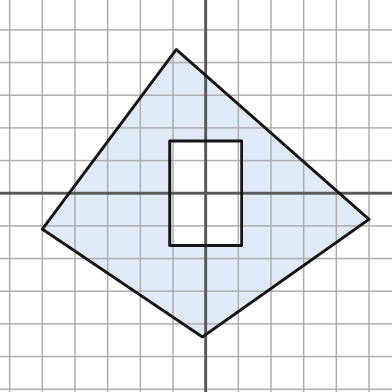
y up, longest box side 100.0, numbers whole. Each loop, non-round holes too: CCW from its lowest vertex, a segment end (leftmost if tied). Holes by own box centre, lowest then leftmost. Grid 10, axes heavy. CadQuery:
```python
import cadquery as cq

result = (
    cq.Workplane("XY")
    .moveTo(-1.0, -44.0)
    .lineTo(50.0, -8.0)
    .lineTo(-9.0, 44.0)
    .lineTo(-50.0, -11.0)
    .close()
    .moveTo(-11.0, -16.0)
    .lineTo(11.0, -16.0)
    .lineTo(11.0, 16.0)
    .lineTo(-11.0, 16.0)
    .close()
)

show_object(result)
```